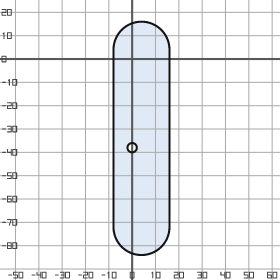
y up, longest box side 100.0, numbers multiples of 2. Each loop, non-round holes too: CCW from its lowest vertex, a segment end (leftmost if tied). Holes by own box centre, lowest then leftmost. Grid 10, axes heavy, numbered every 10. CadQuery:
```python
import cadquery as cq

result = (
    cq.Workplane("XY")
    .moveTo(-8.0, -72.0)
    .threePointArc((4.0, -84.0), (16.0, -72.0))
    .lineTo(16.0, 4.0)
    .threePointArc((4.0, 16.0), (-8.0, 4.0))
    .close()
    .moveTo(0.0, -38.0)
    .circle(2.0)
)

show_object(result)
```